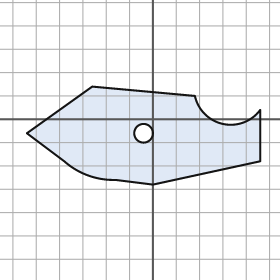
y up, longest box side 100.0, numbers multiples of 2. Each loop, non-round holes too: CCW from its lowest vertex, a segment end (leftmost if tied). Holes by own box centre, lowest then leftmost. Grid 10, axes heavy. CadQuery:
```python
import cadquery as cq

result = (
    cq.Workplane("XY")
    .moveTo(0.0, -28.0)
    .lineTo(46.0, -18.0)
    .lineTo(46.0, 4.0)
    .threePointArc((30.0, -2.0), (18.0, 10.0))
    .lineTo(-26.0, 14.0)
    .lineTo(-54.0, -6.0)
    .lineTo(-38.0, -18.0)
    .threePointArc((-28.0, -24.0), (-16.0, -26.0))
    .close()
    .moveTo(-4.0, -6.0)
    .circle(4.0)
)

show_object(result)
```